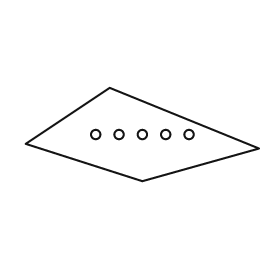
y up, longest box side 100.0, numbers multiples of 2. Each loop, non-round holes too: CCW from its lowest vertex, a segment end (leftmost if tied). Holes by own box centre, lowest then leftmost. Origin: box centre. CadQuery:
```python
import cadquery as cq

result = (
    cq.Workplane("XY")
    .moveTo(0.0, -20.0)
    .lineTo(50.0, -6.0)
    .lineTo(-14.0, 20.0)
    .lineTo(-50.0, -4.0)
    .close()
    .moveTo(-20.0, 0.0)
    .circle(2.0)
    .moveTo(-10.0, 0.0)
    .circle(2.0)
    .moveTo(0.0, 0.0)
    .circle(2.0)
    .moveTo(10.0, 0.0)
    .circle(2.0)
    .moveTo(20.0, 0.0)
    .circle(2.0)
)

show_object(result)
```